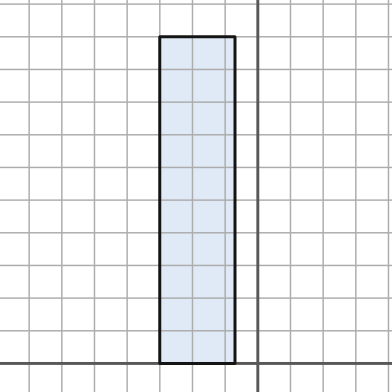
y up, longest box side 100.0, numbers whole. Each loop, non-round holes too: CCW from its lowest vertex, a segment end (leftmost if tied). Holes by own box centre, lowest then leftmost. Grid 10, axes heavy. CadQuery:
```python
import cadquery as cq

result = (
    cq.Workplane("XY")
    .moveTo(-30.0, 0.0)
    .lineTo(-7.0, 0.0)
    .lineTo(-7.0, 100.0)
    .lineTo(-30.0, 100.0)
    .close()
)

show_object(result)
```